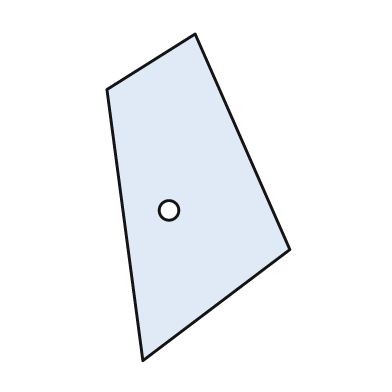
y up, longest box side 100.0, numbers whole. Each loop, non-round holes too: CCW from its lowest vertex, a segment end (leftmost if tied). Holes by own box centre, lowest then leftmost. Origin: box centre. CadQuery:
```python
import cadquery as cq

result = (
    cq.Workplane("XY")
    .moveTo(-17.0, -50.0)
    .lineTo(28.0, -16.0)
    .lineTo(-1.0, 50.0)
    .lineTo(-28.0, 33.0)
    .close()
    .moveTo(-9.0, -4.0)
    .circle(3.0)
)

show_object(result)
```